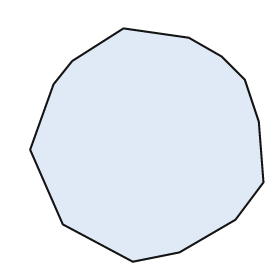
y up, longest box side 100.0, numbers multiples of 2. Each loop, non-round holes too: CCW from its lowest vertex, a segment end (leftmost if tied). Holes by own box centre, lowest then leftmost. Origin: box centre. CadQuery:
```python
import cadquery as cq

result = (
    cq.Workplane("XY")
    .moveTo(-6.0, -50.0)
    .lineTo(14.0, -46.0)
    .lineTo(38.0, -32.0)
    .lineTo(50.0, -16.0)
    .lineTo(48.0, 10.0)
    .lineTo(42.0, 28.0)
    .lineTo(32.0, 38.0)
    .lineTo(18.0, 46.0)
    .lineTo(-10.0, 50.0)
    .lineTo(-32.0, 36.0)
    .lineTo(-40.0, 26.0)
    .lineTo(-50.0, -2.0)
    .lineTo(-36.0, -34.0)
    .close()
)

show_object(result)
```